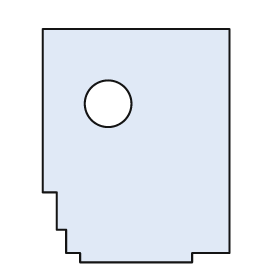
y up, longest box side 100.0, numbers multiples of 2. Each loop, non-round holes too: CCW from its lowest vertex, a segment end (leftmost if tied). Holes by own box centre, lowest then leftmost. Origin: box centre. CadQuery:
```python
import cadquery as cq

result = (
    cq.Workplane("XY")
    .moveTo(-24.0, -50.0)
    .lineTo(24.0, -50.0)
    .lineTo(24.0, -46.0)
    .lineTo(40.0, -46.0)
    .lineTo(40.0, 50.0)
    .lineTo(-40.0, 50.0)
    .lineTo(-40.0, -20.0)
    .lineTo(-34.0, -20.0)
    .lineTo(-34.0, -36.0)
    .lineTo(-30.0, -36.0)
    .lineTo(-30.0, -46.0)
    .lineTo(-24.0, -46.0)
    .close()
    .moveTo(-12.0, 18.0)
    .circle(10.0)
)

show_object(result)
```